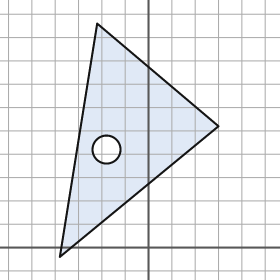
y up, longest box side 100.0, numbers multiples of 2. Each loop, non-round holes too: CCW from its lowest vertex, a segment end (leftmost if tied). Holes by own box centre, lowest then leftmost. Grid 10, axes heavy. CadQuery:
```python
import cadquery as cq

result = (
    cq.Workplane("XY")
    .moveTo(-38.0, -4.0)
    .lineTo(30.0, 52.0)
    .lineTo(-22.0, 96.0)
    .close()
    .moveTo(-18.0, 42.0)
    .circle(6.0)
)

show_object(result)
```